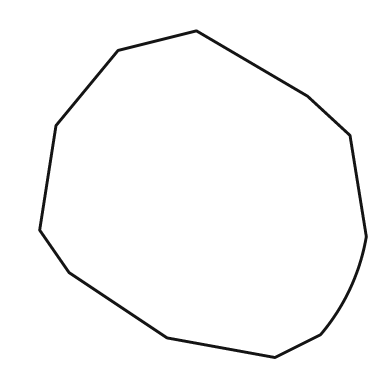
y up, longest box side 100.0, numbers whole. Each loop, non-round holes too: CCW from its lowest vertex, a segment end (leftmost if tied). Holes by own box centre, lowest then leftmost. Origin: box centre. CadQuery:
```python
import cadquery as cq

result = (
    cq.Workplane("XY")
    .moveTo(22.0, -50.0)
    .lineTo(36.0, -43.0)
    .threePointArc((45.0, -29.0), (50.0, -13.0))
    .lineTo(45.0, 18.0)
    .lineTo(32.0, 30.0)
    .lineTo(-2.0, 50.0)
    .lineTo(-26.0, 44.0)
    .lineTo(-45.0, 21.0)
    .lineTo(-50.0, -11.0)
    .lineTo(-41.0, -24.0)
    .lineTo(-11.0, -44.0)
    .close()
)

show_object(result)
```